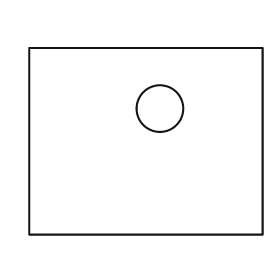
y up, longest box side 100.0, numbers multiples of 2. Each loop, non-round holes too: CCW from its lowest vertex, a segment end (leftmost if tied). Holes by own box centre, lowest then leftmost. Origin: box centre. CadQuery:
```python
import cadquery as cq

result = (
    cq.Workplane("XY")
    .moveTo(-50.0, -40.0)
    .lineTo(50.0, -40.0)
    .lineTo(50.0, 40.0)
    .lineTo(-50.0, 40.0)
    .close()
    .moveTo(6.0, 14.0)
    .circle(10.0)
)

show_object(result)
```